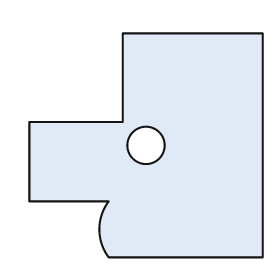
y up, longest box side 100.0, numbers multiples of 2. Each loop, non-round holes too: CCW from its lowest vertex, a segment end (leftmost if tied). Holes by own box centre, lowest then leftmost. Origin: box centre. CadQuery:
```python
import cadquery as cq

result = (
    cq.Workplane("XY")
    .moveTo(-16.0, -48.0)
    .lineTo(50.0, -48.0)
    .lineTo(50.0, 48.0)
    .lineTo(-10.0, 48.0)
    .lineTo(-10.0, 10.0)
    .lineTo(-50.0, 10.0)
    .lineTo(-50.0, -24.0)
    .lineTo(-16.0, -24.0)
    .threePointArc((-20.0, -36.0), (-16.0, -48.0))
    .close()
    .moveTo(0.0, 0.0)
    .circle(8.0)
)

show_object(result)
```